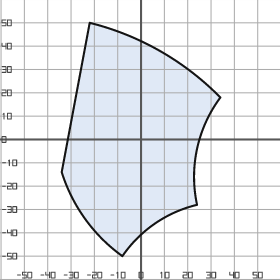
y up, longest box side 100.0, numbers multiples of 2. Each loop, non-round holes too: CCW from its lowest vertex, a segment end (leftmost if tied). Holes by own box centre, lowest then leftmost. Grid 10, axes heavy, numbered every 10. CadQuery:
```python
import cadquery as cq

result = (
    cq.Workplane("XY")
    .moveTo(-8.0, -50.0)
    .threePointArc((6.0, -36.0), (24.0, -28.0))
    .threePointArc((24.0, -4.0), (34.0, 18.0))
    .threePointArc((8.0, 38.0), (-22.0, 50.0))
    .lineTo(-34.0, -14.0)
    .threePointArc((-24.0, -34.0), (-8.0, -50.0))
    .close()
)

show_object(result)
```